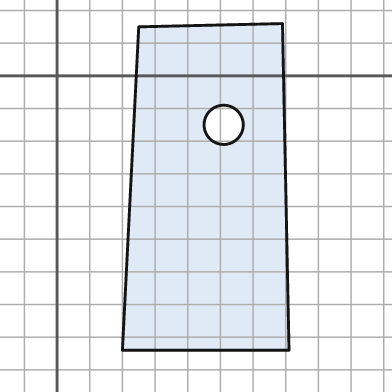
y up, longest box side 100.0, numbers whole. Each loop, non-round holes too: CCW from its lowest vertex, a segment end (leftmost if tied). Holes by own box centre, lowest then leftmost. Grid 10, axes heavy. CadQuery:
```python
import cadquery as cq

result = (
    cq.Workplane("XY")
    .moveTo(20.0, -84.0)
    .lineTo(71.0, -84.0)
    .lineTo(69.0, 16.0)
    .lineTo(25.0, 15.0)
    .close()
    .moveTo(51.0, -15.0)
    .circle(6.0)
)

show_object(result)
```